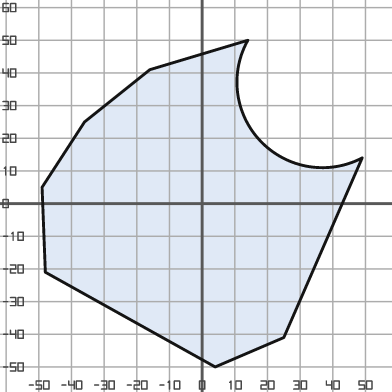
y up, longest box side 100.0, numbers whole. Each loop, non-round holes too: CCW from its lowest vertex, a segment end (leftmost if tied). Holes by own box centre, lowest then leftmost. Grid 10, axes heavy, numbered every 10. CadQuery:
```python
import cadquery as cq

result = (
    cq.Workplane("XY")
    .moveTo(4.0, -50.0)
    .lineTo(25.0, -41.0)
    .lineTo(49.0, 14.0)
    .threePointArc((18.0, 19.0), (14.0, 50.0))
    .lineTo(-16.0, 41.0)
    .lineTo(-36.0, 25.0)
    .lineTo(-49.0, 5.0)
    .lineTo(-48.0, -21.0)
    .close()
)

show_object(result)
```